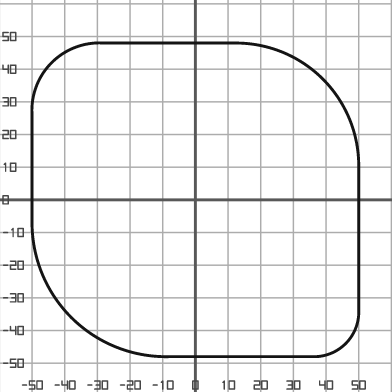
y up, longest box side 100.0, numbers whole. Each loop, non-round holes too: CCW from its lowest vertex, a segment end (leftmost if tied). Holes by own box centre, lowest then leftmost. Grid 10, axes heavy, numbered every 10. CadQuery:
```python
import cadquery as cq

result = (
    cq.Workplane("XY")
    .moveTo(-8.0, -48.0)
    .lineTo(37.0, -48.0)
    .threePointArc((46.0, -44.0), (50.0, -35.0))
    .lineTo(50.0, 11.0)
    .threePointArc((39.0, 37.0), (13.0, 48.0))
    .lineTo(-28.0, 48.0)
    .threePointArc((-44.0, 42.0), (-50.0, 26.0))
    .lineTo(-50.0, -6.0)
    .threePointArc((-38.0, -36.0), (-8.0, -48.0))
    .close()
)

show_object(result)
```